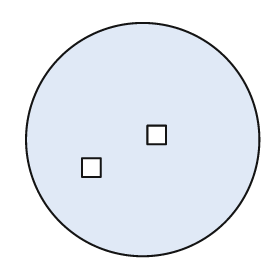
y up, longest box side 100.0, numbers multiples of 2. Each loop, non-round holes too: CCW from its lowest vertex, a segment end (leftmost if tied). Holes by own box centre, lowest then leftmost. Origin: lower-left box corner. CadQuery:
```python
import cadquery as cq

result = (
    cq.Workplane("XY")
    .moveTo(50.0, 50.0)
    .circle(50.0)
    .moveTo(24.0, 34.0)
    .lineTo(32.0, 34.0)
    .lineTo(32.0, 42.0)
    .lineTo(24.0, 42.0)
    .close()
    .moveTo(52.0, 48.0)
    .lineTo(60.0, 48.0)
    .lineTo(60.0, 56.0)
    .lineTo(52.0, 56.0)
    .close()
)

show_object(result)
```